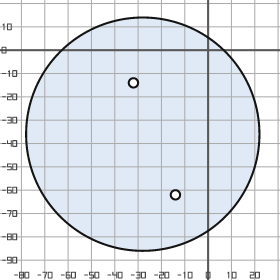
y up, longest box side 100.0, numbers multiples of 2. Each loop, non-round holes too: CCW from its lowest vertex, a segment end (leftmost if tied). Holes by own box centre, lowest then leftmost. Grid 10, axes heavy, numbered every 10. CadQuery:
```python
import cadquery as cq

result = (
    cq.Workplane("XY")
    .moveTo(-28.0, -36.0)
    .circle(50.0)
    .moveTo(-14.0, -62.0)
    .circle(2.0)
    .moveTo(-32.0, -14.0)
    .circle(2.0)
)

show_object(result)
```